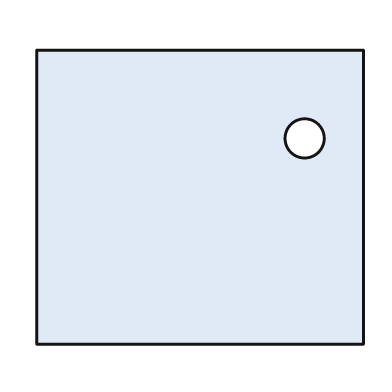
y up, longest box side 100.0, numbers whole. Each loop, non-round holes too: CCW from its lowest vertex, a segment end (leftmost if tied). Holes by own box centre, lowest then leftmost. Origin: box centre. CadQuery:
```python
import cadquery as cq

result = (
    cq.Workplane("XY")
    .moveTo(-50.0, -45.0)
    .lineTo(50.0, -45.0)
    .lineTo(50.0, 45.0)
    .lineTo(-50.0, 45.0)
    .close()
    .moveTo(32.0, 18.0)
    .circle(6.0)
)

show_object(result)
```